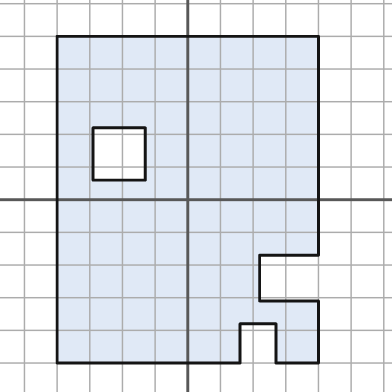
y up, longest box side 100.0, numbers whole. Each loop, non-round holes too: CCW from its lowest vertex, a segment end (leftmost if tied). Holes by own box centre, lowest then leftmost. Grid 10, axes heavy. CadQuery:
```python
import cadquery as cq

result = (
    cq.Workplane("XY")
    .moveTo(-40.0, -50.0)
    .lineTo(16.0, -50.0)
    .lineTo(16.0, -38.0)
    .lineTo(27.0, -38.0)
    .lineTo(27.0, -50.0)
    .lineTo(40.0, -50.0)
    .lineTo(40.0, -31.0)
    .lineTo(22.0, -31.0)
    .lineTo(22.0, -17.0)
    .lineTo(40.0, -17.0)
    .lineTo(40.0, 50.0)
    .lineTo(-40.0, 50.0)
    .close()
    .moveTo(-29.0, 6.0)
    .lineTo(-13.0, 6.0)
    .lineTo(-13.0, 22.0)
    .lineTo(-29.0, 22.0)
    .close()
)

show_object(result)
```